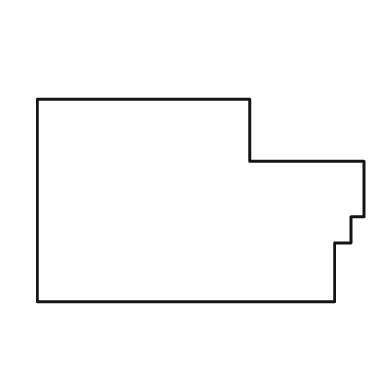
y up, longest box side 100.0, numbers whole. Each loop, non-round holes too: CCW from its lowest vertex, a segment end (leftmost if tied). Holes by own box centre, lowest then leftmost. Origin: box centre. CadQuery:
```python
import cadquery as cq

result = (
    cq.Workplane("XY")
    .moveTo(-50.0, -31.0)
    .lineTo(41.0, -31.0)
    .lineTo(41.0, -13.0)
    .lineTo(46.0, -13.0)
    .lineTo(46.0, -5.0)
    .lineTo(50.0, -5.0)
    .lineTo(50.0, 12.0)
    .lineTo(15.0, 12.0)
    .lineTo(15.0, 31.0)
    .lineTo(-50.0, 31.0)
    .close()
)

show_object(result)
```